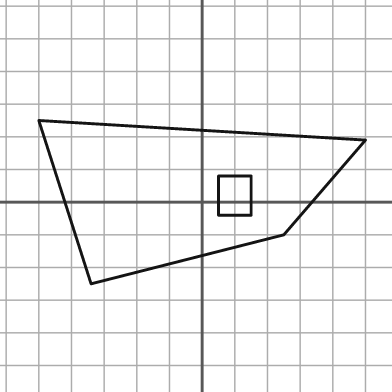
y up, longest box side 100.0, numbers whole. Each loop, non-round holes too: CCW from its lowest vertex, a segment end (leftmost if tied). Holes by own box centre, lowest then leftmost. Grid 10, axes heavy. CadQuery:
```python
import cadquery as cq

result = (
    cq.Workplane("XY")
    .moveTo(-34.0, -25.0)
    .lineTo(25.0, -10.0)
    .lineTo(50.0, 19.0)
    .lineTo(-50.0, 25.0)
    .close()
    .moveTo(5.0, -4.0)
    .lineTo(15.0, -4.0)
    .lineTo(15.0, 8.0)
    .lineTo(5.0, 8.0)
    .close()
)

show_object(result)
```